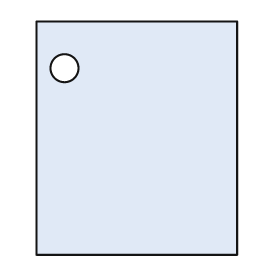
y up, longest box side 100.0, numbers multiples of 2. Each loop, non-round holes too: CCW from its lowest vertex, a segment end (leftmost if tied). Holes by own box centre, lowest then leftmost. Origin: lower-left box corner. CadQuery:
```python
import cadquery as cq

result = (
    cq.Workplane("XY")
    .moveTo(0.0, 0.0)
    .lineTo(86.0, 0.0)
    .lineTo(86.0, 100.0)
    .lineTo(0.0, 100.0)
    .close()
    .moveTo(12.0, 80.0)
    .circle(6.0)
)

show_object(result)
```